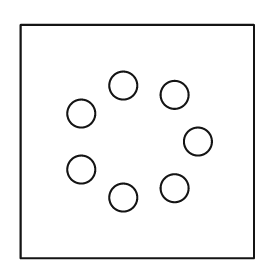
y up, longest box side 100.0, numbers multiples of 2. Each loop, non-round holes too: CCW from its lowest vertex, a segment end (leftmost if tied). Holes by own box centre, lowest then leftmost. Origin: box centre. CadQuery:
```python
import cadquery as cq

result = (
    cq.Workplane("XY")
    .moveTo(-50.0, -50.0)
    .lineTo(50.0, -50.0)
    .lineTo(50.0, 50.0)
    .lineTo(-50.0, 50.0)
    .close()
    .moveTo(-6.0, -24.0)
    .circle(6.0)
    .moveTo(16.0, -20.0)
    .circle(6.0)
    .moveTo(-24.0, -12.0)
    .circle(6.0)
    .moveTo(26.0, 0.0)
    .circle(6.0)
    .moveTo(-24.0, 12.0)
    .circle(6.0)
    .moveTo(16.0, 20.0)
    .circle(6.0)
    .moveTo(-6.0, 24.0)
    .circle(6.0)
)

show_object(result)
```